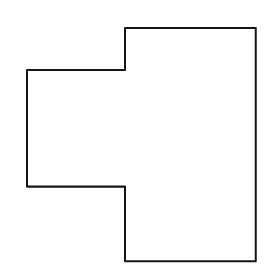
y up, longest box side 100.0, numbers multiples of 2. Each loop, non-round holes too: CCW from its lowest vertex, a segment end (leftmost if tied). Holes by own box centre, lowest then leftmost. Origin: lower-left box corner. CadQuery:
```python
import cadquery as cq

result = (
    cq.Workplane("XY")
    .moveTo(42.0, 0.0)
    .lineTo(98.0, 0.0)
    .lineTo(98.0, 100.0)
    .lineTo(42.0, 100.0)
    .lineTo(42.0, 82.0)
    .lineTo(0.0, 82.0)
    .lineTo(0.0, 32.0)
    .lineTo(42.0, 32.0)
    .close()
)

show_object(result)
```